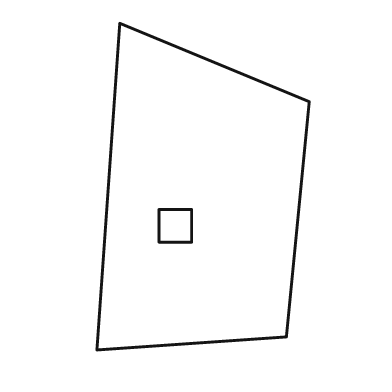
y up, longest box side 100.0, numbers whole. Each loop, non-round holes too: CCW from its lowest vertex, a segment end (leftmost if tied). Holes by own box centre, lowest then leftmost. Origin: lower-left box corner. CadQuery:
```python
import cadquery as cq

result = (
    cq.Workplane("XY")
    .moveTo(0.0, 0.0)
    .lineTo(58.0, 4.0)
    .lineTo(65.0, 76.0)
    .lineTo(7.0, 100.0)
    .close()
    .moveTo(19.0, 33.0)
    .lineTo(29.0, 33.0)
    .lineTo(29.0, 43.0)
    .lineTo(19.0, 43.0)
    .close()
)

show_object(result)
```